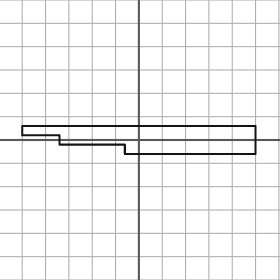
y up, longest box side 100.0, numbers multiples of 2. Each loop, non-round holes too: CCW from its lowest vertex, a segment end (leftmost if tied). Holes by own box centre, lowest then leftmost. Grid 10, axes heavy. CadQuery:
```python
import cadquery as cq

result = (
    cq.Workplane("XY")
    .moveTo(-6.0, -6.0)
    .lineTo(50.0, -6.0)
    .lineTo(50.0, 6.0)
    .lineTo(-50.0, 6.0)
    .lineTo(-50.0, 2.0)
    .lineTo(-34.0, 2.0)
    .lineTo(-34.0, -2.0)
    .lineTo(-6.0, -2.0)
    .close()
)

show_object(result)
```